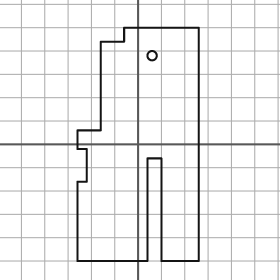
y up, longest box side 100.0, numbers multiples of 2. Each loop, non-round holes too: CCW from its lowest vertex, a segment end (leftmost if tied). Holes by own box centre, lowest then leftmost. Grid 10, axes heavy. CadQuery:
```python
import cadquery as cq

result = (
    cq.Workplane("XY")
    .moveTo(-26.0, -50.0)
    .lineTo(4.0, -50.0)
    .lineTo(4.0, -6.0)
    .lineTo(10.0, -6.0)
    .lineTo(10.0, -50.0)
    .lineTo(26.0, -50.0)
    .lineTo(26.0, 50.0)
    .lineTo(-6.0, 50.0)
    .lineTo(-6.0, 44.0)
    .lineTo(-16.0, 44.0)
    .lineTo(-16.0, 6.0)
    .lineTo(-26.0, 6.0)
    .lineTo(-26.0, -2.0)
    .lineTo(-22.0, -2.0)
    .lineTo(-22.0, -16.0)
    .lineTo(-26.0, -16.0)
    .close()
    .moveTo(6.0, 38.0)
    .circle(2.0)
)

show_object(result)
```